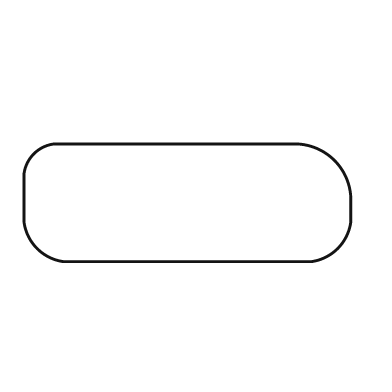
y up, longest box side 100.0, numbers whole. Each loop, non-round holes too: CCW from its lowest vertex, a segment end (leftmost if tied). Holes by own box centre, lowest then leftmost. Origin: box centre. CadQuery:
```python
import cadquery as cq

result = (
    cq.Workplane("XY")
    .moveTo(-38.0, -18.0)
    .lineTo(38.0, -18.0)
    .threePointArc((46.0, -14.0), (50.0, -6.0))
    .lineTo(50.0, 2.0)
    .threePointArc((45.0, 13.0), (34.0, 18.0))
    .lineTo(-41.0, 18.0)
    .threePointArc((-47.0, 15.0), (-50.0, 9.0))
    .lineTo(-50.0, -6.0)
    .threePointArc((-46.0, -14.0), (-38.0, -18.0))
    .close()
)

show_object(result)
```